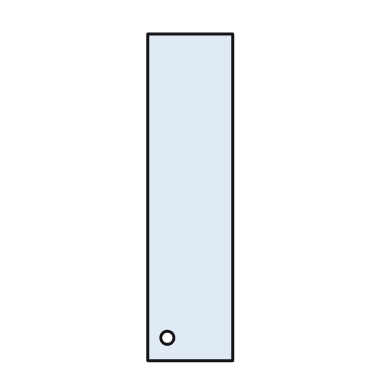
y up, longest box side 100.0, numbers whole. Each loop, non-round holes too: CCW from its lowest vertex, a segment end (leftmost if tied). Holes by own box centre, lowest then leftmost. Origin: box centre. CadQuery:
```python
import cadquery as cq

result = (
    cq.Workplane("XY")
    .moveTo(-13.0, -50.0)
    .lineTo(13.0, -50.0)
    .lineTo(13.0, 50.0)
    .lineTo(-13.0, 50.0)
    .close()
    .moveTo(-7.0, -43.0)
    .circle(2.0)
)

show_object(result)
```